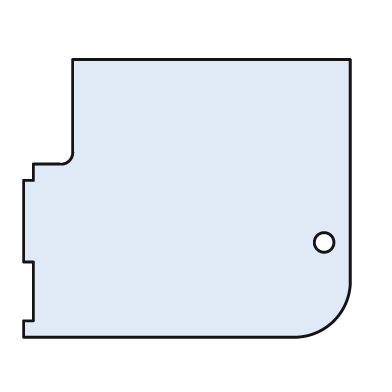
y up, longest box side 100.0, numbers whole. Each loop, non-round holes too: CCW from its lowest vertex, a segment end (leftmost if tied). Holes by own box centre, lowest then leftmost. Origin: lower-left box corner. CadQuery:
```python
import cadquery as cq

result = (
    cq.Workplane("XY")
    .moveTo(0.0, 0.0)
    .lineTo(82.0, 0.0)
    .threePointArc((95.0, 5.0), (100.0, 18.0))
    .lineTo(100.0, 85.0)
    .lineTo(15.0, 85.0)
    .lineTo(15.0, 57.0)
    .threePointArc((14.0, 54.0), (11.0, 53.0))
    .lineTo(3.0, 53.0)
    .lineTo(3.0, 48.0)
    .lineTo(0.0, 48.0)
    .lineTo(0.0, 23.0)
    .lineTo(3.0, 23.0)
    .lineTo(3.0, 5.0)
    .lineTo(0.0, 5.0)
    .close()
    .moveTo(92.0, 29.0)
    .circle(3.0)
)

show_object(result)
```